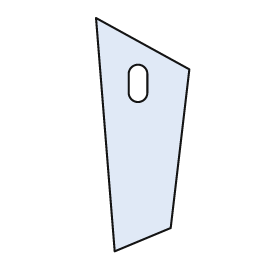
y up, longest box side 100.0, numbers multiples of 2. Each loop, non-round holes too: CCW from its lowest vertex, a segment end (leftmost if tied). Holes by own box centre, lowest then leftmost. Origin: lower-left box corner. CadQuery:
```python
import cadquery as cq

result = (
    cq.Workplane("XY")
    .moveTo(8.0, 0.0)
    .lineTo(32.0, 10.0)
    .lineTo(40.0, 78.0)
    .lineTo(0.0, 100.0)
    .close()
    .moveTo(14.0, 68.0)
    .threePointArc((18.0, 64.0), (22.0, 68.0))
    .lineTo(22.0, 76.0)
    .threePointArc((18.0, 80.0), (14.0, 76.0))
    .close()
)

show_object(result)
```